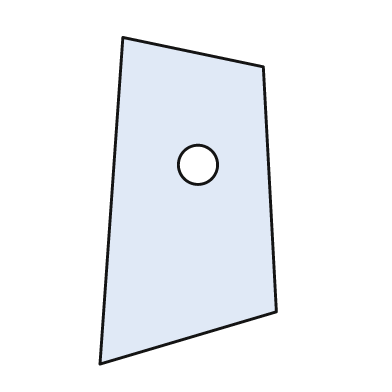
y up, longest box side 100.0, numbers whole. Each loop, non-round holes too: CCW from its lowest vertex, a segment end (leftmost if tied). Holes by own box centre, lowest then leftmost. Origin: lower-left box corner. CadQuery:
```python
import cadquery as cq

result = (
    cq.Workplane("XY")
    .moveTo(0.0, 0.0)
    .lineTo(54.0, 16.0)
    .lineTo(50.0, 91.0)
    .lineTo(7.0, 100.0)
    .close()
    .moveTo(30.0, 61.0)
    .circle(6.0)
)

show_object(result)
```